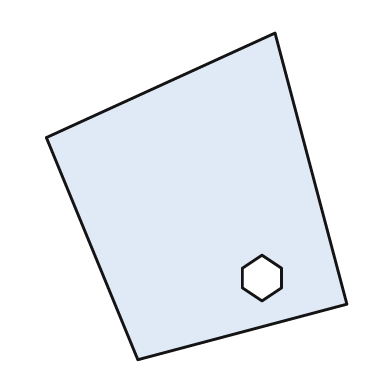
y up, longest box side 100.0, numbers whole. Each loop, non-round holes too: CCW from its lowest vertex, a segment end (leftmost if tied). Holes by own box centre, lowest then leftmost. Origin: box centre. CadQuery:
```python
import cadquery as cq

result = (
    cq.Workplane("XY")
    .moveTo(-18.0, -50.0)
    .lineTo(46.0, -33.0)
    .lineTo(24.0, 50.0)
    .lineTo(-46.0, 18.0)
    .close()
    .moveTo(20.0, -32.0)
    .lineTo(26.0, -28.0)
    .lineTo(26.0, -22.0)
    .lineTo(20.0, -18.0)
    .lineTo(14.0, -22.0)
    .lineTo(14.0, -28.0)
    .close()
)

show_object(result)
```